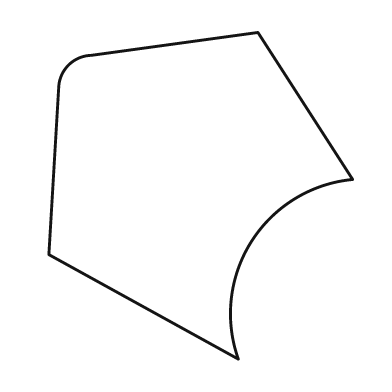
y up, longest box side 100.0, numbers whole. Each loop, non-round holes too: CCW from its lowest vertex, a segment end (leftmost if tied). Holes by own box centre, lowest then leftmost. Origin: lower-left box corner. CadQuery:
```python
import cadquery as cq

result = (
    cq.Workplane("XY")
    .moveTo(58.0, 0.0)
    .threePointArc((62.0, 36.0), (93.0, 55.0))
    .lineTo(64.0, 100.0)
    .lineTo(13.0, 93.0)
    .threePointArc((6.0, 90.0), (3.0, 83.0))
    .lineTo(0.0, 32.0)
    .close()
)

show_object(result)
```